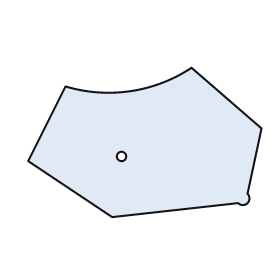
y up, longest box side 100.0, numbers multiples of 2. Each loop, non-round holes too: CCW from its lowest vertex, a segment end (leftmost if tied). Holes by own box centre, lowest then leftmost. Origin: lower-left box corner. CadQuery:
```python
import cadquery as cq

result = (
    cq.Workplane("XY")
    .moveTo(36.0, 0.0)
    .lineTo(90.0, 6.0)
    .threePointArc((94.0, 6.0), (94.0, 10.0))
    .lineTo(100.0, 38.0)
    .lineTo(70.0, 64.0)
    .threePointArc((44.0, 54.0), (16.0, 56.0))
    .lineTo(0.0, 24.0)
    .close()
    .moveTo(40.0, 26.0)
    .circle(2.0)
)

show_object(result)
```